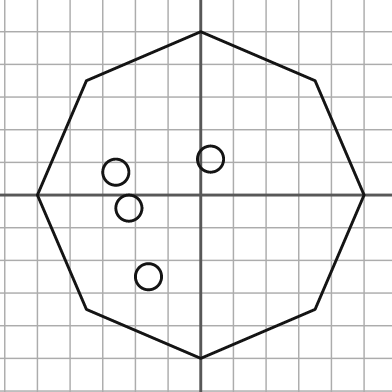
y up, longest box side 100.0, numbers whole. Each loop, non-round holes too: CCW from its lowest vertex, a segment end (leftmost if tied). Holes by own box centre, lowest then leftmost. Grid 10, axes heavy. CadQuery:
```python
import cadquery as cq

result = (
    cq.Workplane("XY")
    .moveTo(0.0, -50.0)
    .lineTo(35.0, -35.0)
    .lineTo(50.0, 0.0)
    .lineTo(35.0, 35.0)
    .lineTo(0.0, 50.0)
    .lineTo(-35.0, 35.0)
    .lineTo(-50.0, 0.0)
    .lineTo(-35.0, -35.0)
    .close()
    .moveTo(-16.0, -25.0)
    .circle(4.0)
    .moveTo(-22.0, -4.0)
    .circle(4.0)
    .moveTo(-26.0, 7.0)
    .circle(4.0)
    .moveTo(3.0, 11.0)
    .circle(4.0)
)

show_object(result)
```